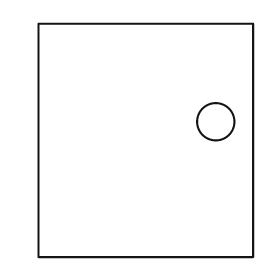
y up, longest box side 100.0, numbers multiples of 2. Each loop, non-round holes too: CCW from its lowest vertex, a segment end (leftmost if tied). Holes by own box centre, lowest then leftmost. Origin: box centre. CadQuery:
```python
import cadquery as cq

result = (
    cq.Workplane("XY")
    .moveTo(-46.0, -50.0)
    .lineTo(46.0, -50.0)
    .lineTo(46.0, 50.0)
    .lineTo(-46.0, 50.0)
    .close()
    .moveTo(30.0, 8.0)
    .circle(8.0)
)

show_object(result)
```